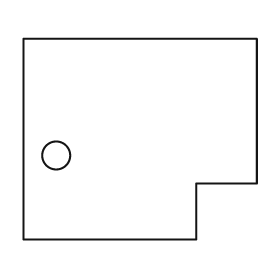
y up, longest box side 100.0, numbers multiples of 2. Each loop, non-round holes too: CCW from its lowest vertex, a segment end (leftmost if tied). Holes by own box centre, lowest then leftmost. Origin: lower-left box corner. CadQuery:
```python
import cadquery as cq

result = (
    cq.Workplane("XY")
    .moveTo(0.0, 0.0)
    .lineTo(74.0, 0.0)
    .lineTo(74.0, 24.0)
    .lineTo(100.0, 24.0)
    .lineTo(100.0, 86.0)
    .lineTo(0.0, 86.0)
    .close()
    .moveTo(14.0, 36.0)
    .circle(6.0)
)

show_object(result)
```